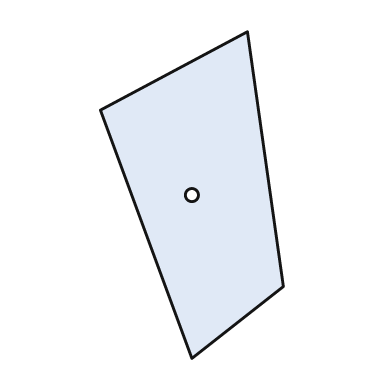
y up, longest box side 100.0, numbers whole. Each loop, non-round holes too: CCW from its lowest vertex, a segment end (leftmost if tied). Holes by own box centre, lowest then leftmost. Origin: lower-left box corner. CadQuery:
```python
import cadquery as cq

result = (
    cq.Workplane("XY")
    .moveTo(28.0, 0.0)
    .lineTo(56.0, 22.0)
    .lineTo(45.0, 100.0)
    .lineTo(0.0, 76.0)
    .close()
    .moveTo(28.0, 50.0)
    .circle(2.0)
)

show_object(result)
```